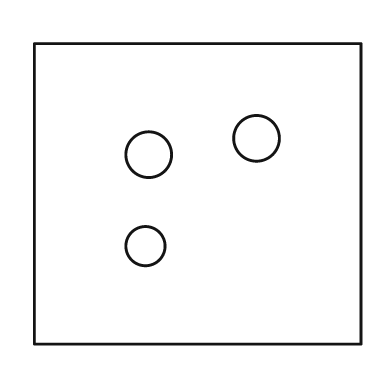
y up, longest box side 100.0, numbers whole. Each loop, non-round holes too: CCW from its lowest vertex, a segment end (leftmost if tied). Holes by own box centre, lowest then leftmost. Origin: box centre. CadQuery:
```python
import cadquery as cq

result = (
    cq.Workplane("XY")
    .moveTo(-50.0, -46.0)
    .lineTo(50.0, -46.0)
    .lineTo(50.0, 46.0)
    .lineTo(-50.0, 46.0)
    .close()
    .moveTo(-16.0, -16.0)
    .circle(6.0)
    .moveTo(-15.0, 12.0)
    .circle(7.0)
    .moveTo(18.0, 17.0)
    .circle(7.0)
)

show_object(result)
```